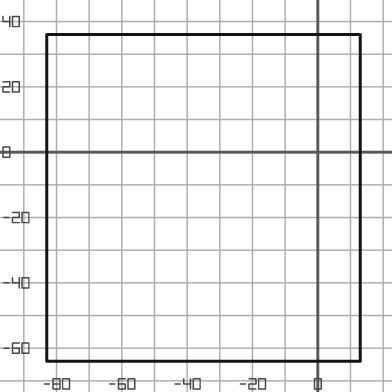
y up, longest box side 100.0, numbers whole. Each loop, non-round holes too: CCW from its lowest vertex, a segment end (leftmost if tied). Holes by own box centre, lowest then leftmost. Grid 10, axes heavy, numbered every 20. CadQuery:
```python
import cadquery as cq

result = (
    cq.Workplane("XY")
    .moveTo(-83.0, -64.0)
    .lineTo(13.0, -64.0)
    .lineTo(13.0, 36.0)
    .lineTo(-83.0, 36.0)
    .close()
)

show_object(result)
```